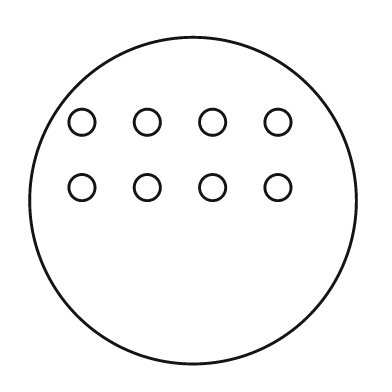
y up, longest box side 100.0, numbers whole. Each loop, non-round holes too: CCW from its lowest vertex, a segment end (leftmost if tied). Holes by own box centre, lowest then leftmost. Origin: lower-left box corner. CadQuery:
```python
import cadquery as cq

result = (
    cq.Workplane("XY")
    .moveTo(50.0, 50.0)
    .circle(50.0)
    .moveTo(16.0, 54.0)
    .circle(4.0)
    .moveTo(36.0, 54.0)
    .circle(4.0)
    .moveTo(56.0, 54.0)
    .circle(4.0)
    .moveTo(76.0, 54.0)
    .circle(4.0)
    .moveTo(16.0, 74.0)
    .circle(4.0)
    .moveTo(36.0, 74.0)
    .circle(4.0)
    .moveTo(56.0, 74.0)
    .circle(4.0)
    .moveTo(76.0, 74.0)
    .circle(4.0)
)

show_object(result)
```